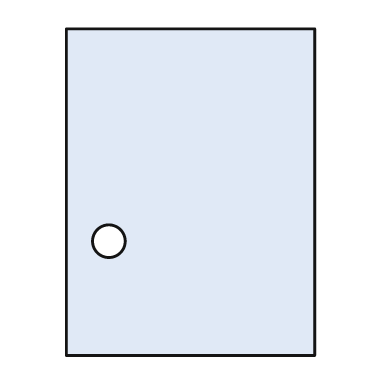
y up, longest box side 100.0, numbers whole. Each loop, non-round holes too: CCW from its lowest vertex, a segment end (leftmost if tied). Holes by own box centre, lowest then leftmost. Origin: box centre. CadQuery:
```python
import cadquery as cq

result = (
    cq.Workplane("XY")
    .moveTo(-38.0, -50.0)
    .lineTo(38.0, -50.0)
    .lineTo(38.0, 50.0)
    .lineTo(-38.0, 50.0)
    .close()
    .moveTo(-25.0, -15.0)
    .circle(5.0)
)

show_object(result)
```